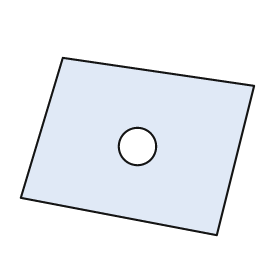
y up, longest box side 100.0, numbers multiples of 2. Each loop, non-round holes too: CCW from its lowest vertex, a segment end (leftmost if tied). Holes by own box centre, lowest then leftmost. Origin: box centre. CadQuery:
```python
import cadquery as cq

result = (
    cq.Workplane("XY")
    .moveTo(34.0, -38.0)
    .lineTo(50.0, 26.0)
    .lineTo(-32.0, 38.0)
    .lineTo(-50.0, -22.0)
    .close()
    .moveTo(0.0, 0.0)
    .circle(8.0)
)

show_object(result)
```